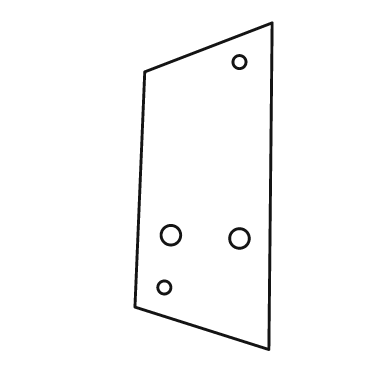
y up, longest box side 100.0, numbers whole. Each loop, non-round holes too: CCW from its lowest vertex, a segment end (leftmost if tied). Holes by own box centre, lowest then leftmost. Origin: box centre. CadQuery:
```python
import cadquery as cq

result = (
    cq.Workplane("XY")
    .moveTo(20.0, -50.0)
    .lineTo(21.0, 50.0)
    .lineTo(-18.0, 35.0)
    .lineTo(-21.0, -37.0)
    .close()
    .moveTo(-12.0, -31.0)
    .circle(2.0)
    .moveTo(11.0, -16.0)
    .circle(3.0)
    .moveTo(-10.0, -15.0)
    .circle(3.0)
    .moveTo(11.0, 38.0)
    .circle(2.0)
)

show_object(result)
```